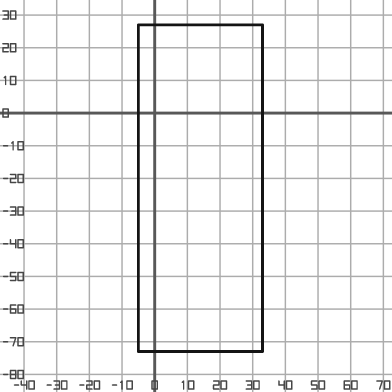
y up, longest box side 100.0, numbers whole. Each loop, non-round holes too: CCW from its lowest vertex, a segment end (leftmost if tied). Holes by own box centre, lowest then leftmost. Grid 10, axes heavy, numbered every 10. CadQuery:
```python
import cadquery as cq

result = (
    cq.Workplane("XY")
    .moveTo(-5.0, -73.0)
    .lineTo(33.0, -73.0)
    .lineTo(33.0, 27.0)
    .lineTo(-5.0, 27.0)
    .close()
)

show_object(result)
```